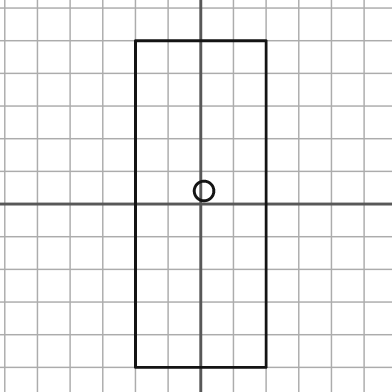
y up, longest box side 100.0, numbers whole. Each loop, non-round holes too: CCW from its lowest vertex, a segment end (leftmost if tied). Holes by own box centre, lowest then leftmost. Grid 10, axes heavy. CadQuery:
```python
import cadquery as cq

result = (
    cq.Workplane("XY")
    .moveTo(-20.0, -50.0)
    .lineTo(20.0, -50.0)
    .lineTo(20.0, 50.0)
    .lineTo(-20.0, 50.0)
    .close()
    .moveTo(1.0, 4.0)
    .circle(3.0)
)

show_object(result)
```